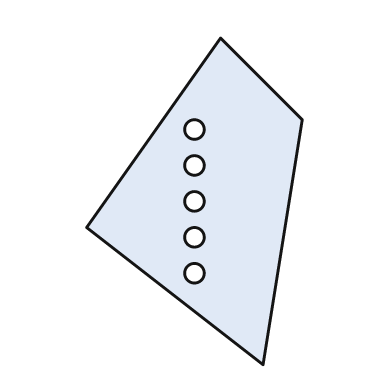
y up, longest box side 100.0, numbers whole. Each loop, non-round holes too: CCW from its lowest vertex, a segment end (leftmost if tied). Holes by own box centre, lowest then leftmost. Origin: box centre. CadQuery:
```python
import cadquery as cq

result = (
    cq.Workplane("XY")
    .moveTo(21.0, -50.0)
    .lineTo(33.0, 25.0)
    .lineTo(8.0, 50.0)
    .lineTo(-33.0, -8.0)
    .close()
    .moveTo(0.0, -22.0)
    .circle(3.0)
    .moveTo(0.0, -11.0)
    .circle(3.0)
    .moveTo(0.0, 0.0)
    .circle(3.0)
    .moveTo(0.0, 11.0)
    .circle(3.0)
    .moveTo(0.0, 22.0)
    .circle(3.0)
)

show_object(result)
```